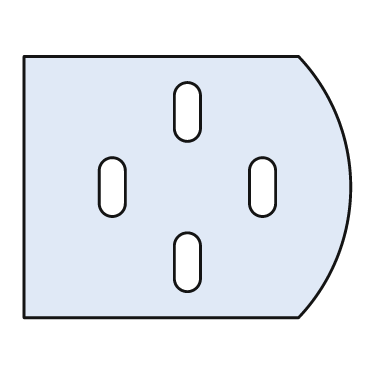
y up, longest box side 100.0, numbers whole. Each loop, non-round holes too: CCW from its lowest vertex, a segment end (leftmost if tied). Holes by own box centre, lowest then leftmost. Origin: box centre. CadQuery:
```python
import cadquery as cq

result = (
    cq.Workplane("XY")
    .moveTo(-50.0, -40.0)
    .lineTo(34.0, -40.0)
    .threePointArc((50.0, 0.0), (34.0, 40.0))
    .lineTo(-50.0, 40.0)
    .close()
    .moveTo(-4.0, -28.0)
    .threePointArc((0.0, -32.0), (4.0, -28.0))
    .lineTo(4.0, -18.0)
    .threePointArc((0.0, -14.0), (-4.0, -18.0))
    .close()
    .moveTo(-27.0, -5.0)
    .threePointArc((-23.0, -9.0), (-19.0, -5.0))
    .lineTo(-19.0, 5.0)
    .threePointArc((-23.0, 9.0), (-27.0, 5.0))
    .close()
    .moveTo(19.0, -5.0)
    .threePointArc((23.0, -9.0), (27.0, -5.0))
    .lineTo(27.0, 5.0)
    .threePointArc((23.0, 9.0), (19.0, 5.0))
    .close()
    .moveTo(-4.0, 18.0)
    .threePointArc((0.0, 14.0), (4.0, 18.0))
    .lineTo(4.0, 28.0)
    .threePointArc((0.0, 32.0), (-4.0, 28.0))
    .close()
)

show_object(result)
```